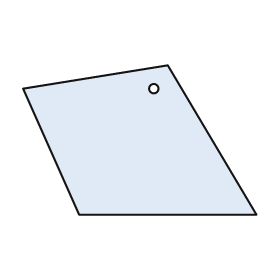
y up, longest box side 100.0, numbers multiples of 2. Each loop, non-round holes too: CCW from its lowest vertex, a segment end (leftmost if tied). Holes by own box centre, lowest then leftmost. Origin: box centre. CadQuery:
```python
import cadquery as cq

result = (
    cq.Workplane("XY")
    .moveTo(-26.0, -32.0)
    .lineTo(50.0, -32.0)
    .lineTo(12.0, 32.0)
    .lineTo(-50.0, 22.0)
    .close()
    .moveTo(6.0, 22.0)
    .circle(2.0)
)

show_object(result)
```